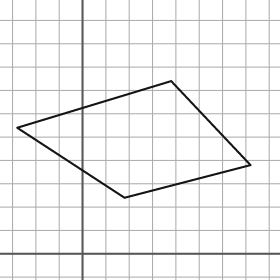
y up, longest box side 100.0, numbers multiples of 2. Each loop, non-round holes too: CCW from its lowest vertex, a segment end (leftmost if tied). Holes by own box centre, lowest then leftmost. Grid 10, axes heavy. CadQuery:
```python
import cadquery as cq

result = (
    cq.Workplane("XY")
    .moveTo(18.0, 24.0)
    .lineTo(72.0, 38.0)
    .lineTo(38.0, 74.0)
    .lineTo(-28.0, 54.0)
    .close()
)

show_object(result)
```